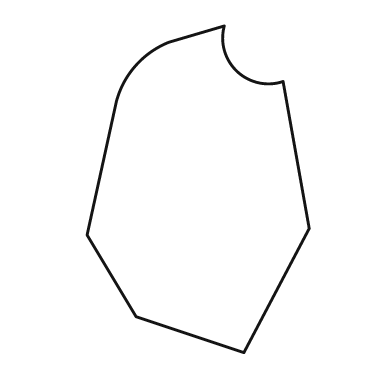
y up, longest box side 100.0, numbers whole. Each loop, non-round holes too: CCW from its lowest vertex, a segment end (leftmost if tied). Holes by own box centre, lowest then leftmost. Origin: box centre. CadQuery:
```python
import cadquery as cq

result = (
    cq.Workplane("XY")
    .moveTo(14.0, -50.0)
    .lineTo(34.0, -12.0)
    .lineTo(26.0, 33.0)
    .threePointArc((12.0, 36.0), (8.0, 50.0))
    .lineTo(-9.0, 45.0)
    .threePointArc((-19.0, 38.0), (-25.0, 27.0))
    .lineTo(-34.0, -14.0)
    .lineTo(-19.0, -39.0)
    .close()
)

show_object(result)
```